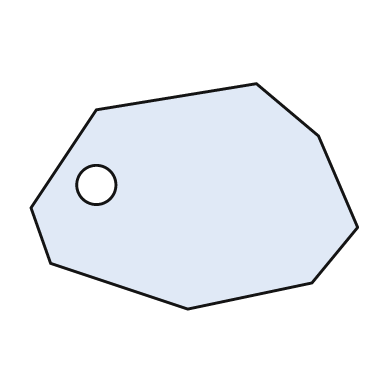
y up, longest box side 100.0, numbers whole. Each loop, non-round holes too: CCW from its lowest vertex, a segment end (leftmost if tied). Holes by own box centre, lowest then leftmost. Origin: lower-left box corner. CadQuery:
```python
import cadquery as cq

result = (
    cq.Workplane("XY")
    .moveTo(48.0, 0.0)
    .lineTo(86.0, 8.0)
    .lineTo(100.0, 25.0)
    .lineTo(88.0, 53.0)
    .lineTo(69.0, 69.0)
    .lineTo(20.0, 61.0)
    .lineTo(0.0, 31.0)
    .lineTo(6.0, 14.0)
    .close()
    .moveTo(20.0, 38.0)
    .circle(6.0)
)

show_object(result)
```